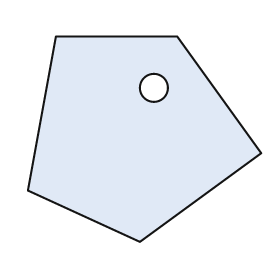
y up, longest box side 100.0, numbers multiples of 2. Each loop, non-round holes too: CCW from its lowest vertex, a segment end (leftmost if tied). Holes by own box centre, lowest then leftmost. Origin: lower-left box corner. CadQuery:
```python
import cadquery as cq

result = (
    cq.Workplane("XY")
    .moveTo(48.0, 0.0)
    .lineTo(100.0, 38.0)
    .lineTo(64.0, 88.0)
    .lineTo(12.0, 88.0)
    .lineTo(0.0, 22.0)
    .close()
    .moveTo(54.0, 66.0)
    .circle(6.0)
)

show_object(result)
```